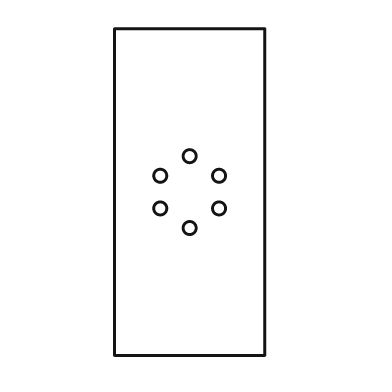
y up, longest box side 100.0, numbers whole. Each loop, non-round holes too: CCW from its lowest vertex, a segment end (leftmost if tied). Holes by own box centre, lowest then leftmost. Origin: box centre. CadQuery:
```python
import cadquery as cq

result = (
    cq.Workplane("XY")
    .moveTo(-23.0, -50.0)
    .lineTo(23.0, -50.0)
    .lineTo(23.0, 50.0)
    .lineTo(-23.0, 50.0)
    .close()
    .moveTo(0.0, -11.0)
    .circle(2.0)
    .moveTo(-9.0, -5.0)
    .circle(2.0)
    .moveTo(9.0, -5.0)
    .circle(2.0)
    .moveTo(-9.0, 5.0)
    .circle(2.0)
    .moveTo(9.0, 5.0)
    .circle(2.0)
    .moveTo(0.0, 11.0)
    .circle(2.0)
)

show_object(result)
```